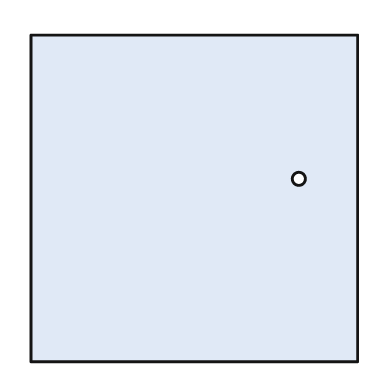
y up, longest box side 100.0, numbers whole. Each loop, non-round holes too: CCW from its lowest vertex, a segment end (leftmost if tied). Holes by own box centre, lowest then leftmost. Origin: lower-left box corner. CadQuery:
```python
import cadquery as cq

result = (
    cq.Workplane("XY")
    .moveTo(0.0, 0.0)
    .lineTo(100.0, 0.0)
    .lineTo(100.0, 100.0)
    .lineTo(0.0, 100.0)
    .close()
    .moveTo(82.0, 56.0)
    .circle(2.0)
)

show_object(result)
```